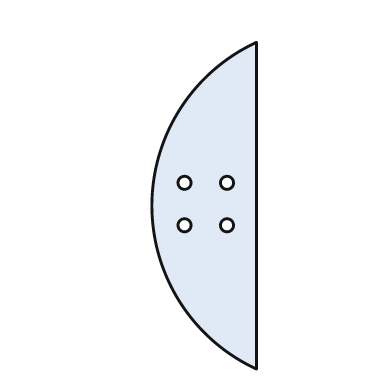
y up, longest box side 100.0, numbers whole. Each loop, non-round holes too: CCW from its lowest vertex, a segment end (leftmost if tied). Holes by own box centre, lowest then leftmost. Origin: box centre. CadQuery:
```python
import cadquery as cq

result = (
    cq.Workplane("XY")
    .moveTo(16.0, -50.0)
    .lineTo(16.0, 50.0)
    .threePointArc((-16.0, 0.0), (16.0, -50.0))
    .close()
    .moveTo(-6.0, -6.0)
    .circle(2.0)
    .moveTo(7.0, -6.0)
    .circle(2.0)
    .moveTo(-6.0, 7.0)
    .circle(2.0)
    .moveTo(7.0, 7.0)
    .circle(2.0)
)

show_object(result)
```